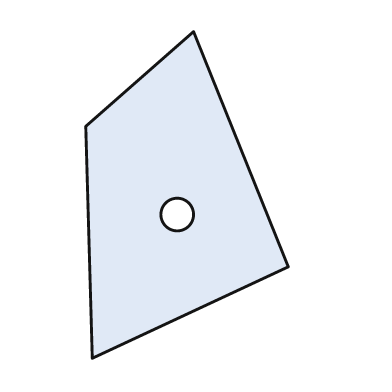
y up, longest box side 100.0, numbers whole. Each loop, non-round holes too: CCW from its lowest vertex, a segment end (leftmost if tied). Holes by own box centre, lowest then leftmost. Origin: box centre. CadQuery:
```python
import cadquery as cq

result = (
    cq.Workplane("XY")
    .moveTo(-29.0, -50.0)
    .lineTo(31.0, -22.0)
    .lineTo(2.0, 50.0)
    .lineTo(-31.0, 21.0)
    .close()
    .moveTo(-3.0, -6.0)
    .circle(5.0)
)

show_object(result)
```